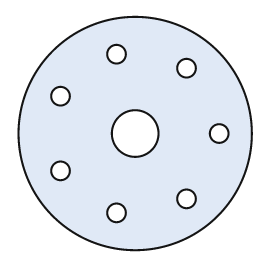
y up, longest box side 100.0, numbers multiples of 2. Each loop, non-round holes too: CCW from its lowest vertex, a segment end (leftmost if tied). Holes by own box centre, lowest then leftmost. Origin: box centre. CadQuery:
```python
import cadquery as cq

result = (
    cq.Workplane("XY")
    .moveTo(0.0, 0.0)
    .circle(50.0)
    .moveTo(-8.0, -34.0)
    .circle(4.0)
    .moveTo(22.0, -28.0)
    .circle(4.0)
    .moveTo(-32.0, -16.0)
    .circle(4.0)
    .moveTo(0.0, 0.0)
    .circle(10.0)
    .moveTo(36.0, 0.0)
    .circle(4.0)
    .moveTo(-32.0, 16.0)
    .circle(4.0)
    .moveTo(22.0, 28.0)
    .circle(4.0)
    .moveTo(-8.0, 34.0)
    .circle(4.0)
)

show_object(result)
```